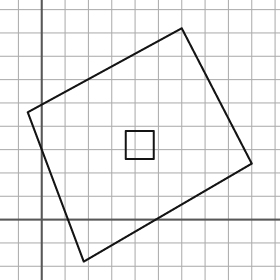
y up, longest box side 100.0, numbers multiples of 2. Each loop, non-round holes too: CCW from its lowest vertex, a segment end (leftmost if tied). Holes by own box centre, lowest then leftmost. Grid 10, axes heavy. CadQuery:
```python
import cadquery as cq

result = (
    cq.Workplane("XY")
    .moveTo(18.0, -18.0)
    .lineTo(90.0, 24.0)
    .lineTo(60.0, 82.0)
    .lineTo(-6.0, 46.0)
    .close()
    .moveTo(36.0, 26.0)
    .lineTo(48.0, 26.0)
    .lineTo(48.0, 38.0)
    .lineTo(36.0, 38.0)
    .close()
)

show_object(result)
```